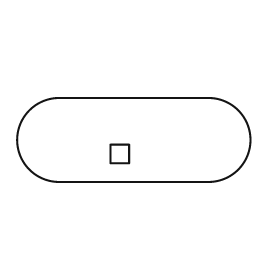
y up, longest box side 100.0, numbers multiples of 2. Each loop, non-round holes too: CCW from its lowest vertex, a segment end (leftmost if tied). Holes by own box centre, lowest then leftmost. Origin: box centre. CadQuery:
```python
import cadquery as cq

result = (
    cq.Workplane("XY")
    .moveTo(-32.0, -18.0)
    .lineTo(32.0, -18.0)
    .threePointArc((50.0, 0.0), (32.0, 18.0))
    .lineTo(-32.0, 18.0)
    .threePointArc((-50.0, 0.0), (-32.0, -18.0))
    .close()
    .moveTo(-10.0, -10.0)
    .lineTo(-2.0, -10.0)
    .lineTo(-2.0, -2.0)
    .lineTo(-10.0, -2.0)
    .close()
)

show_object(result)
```